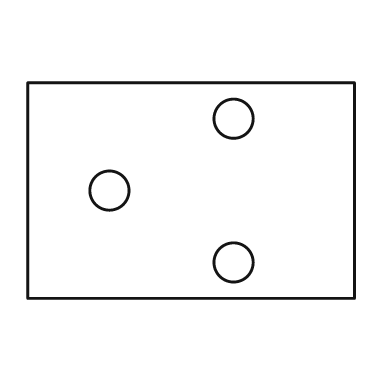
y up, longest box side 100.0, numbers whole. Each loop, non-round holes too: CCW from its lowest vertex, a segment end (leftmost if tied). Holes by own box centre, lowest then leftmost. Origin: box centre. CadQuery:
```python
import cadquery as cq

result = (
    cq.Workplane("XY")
    .moveTo(-50.0, -33.0)
    .lineTo(50.0, -33.0)
    .lineTo(50.0, 33.0)
    .lineTo(-50.0, 33.0)
    .close()
    .moveTo(13.0, -22.0)
    .circle(6.0)
    .moveTo(-25.0, 0.0)
    .circle(6.0)
    .moveTo(13.0, 22.0)
    .circle(6.0)
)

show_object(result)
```